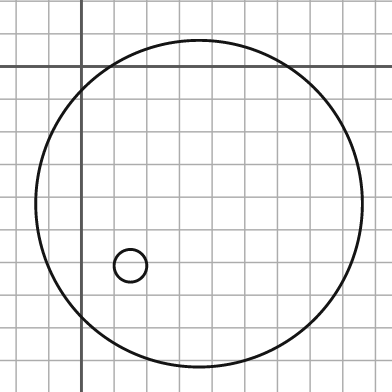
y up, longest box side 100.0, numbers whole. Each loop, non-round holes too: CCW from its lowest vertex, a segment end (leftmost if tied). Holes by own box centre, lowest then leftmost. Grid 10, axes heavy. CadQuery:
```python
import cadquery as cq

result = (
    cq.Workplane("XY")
    .moveTo(36.0, -42.0)
    .circle(50.0)
    .moveTo(15.0, -61.0)
    .circle(5.0)
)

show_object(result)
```